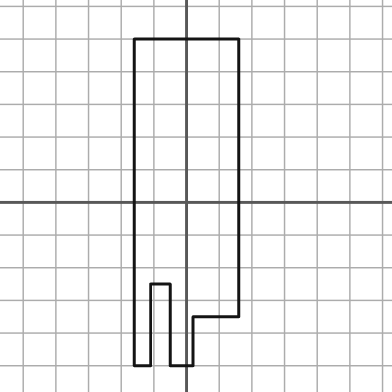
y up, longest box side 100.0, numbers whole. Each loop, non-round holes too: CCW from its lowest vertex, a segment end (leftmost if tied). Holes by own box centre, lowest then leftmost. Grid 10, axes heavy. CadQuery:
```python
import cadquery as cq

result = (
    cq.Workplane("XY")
    .moveTo(-16.0, -50.0)
    .lineTo(-11.0, -50.0)
    .lineTo(-11.0, -25.0)
    .lineTo(-5.0, -25.0)
    .lineTo(-5.0, -50.0)
    .lineTo(2.0, -50.0)
    .lineTo(2.0, -35.0)
    .lineTo(16.0, -35.0)
    .lineTo(16.0, 50.0)
    .lineTo(-16.0, 50.0)
    .close()
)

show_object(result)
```